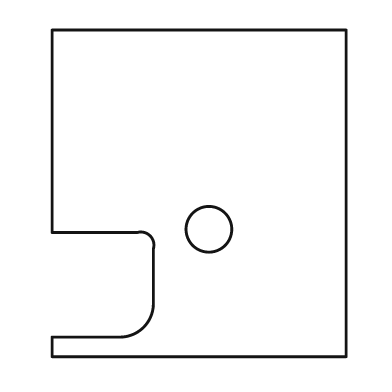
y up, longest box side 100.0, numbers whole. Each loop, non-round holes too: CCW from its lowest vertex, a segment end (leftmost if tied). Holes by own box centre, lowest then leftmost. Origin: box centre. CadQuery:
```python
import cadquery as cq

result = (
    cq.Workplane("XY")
    .moveTo(-45.0, -50.0)
    .lineTo(45.0, -50.0)
    .lineTo(45.0, 50.0)
    .lineTo(-45.0, 50.0)
    .lineTo(-45.0, -12.0)
    .lineTo(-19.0, -12.0)
    .threePointArc((-15.0, -13.0), (-14.0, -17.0))
    .lineTo(-14.0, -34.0)
    .threePointArc((-17.0, -41.0), (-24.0, -44.0))
    .lineTo(-45.0, -44.0)
    .close()
    .moveTo(3.0, -11.0)
    .circle(7.0)
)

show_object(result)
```